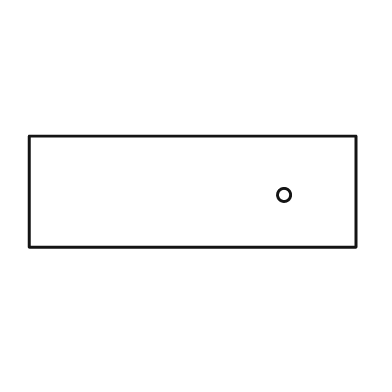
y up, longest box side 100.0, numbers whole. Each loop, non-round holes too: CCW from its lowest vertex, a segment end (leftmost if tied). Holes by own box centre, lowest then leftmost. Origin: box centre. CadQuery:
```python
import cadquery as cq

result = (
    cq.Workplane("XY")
    .moveTo(-50.0, -17.0)
    .lineTo(50.0, -17.0)
    .lineTo(50.0, 17.0)
    .lineTo(-50.0, 17.0)
    .close()
    .moveTo(28.0, -1.0)
    .circle(2.0)
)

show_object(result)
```